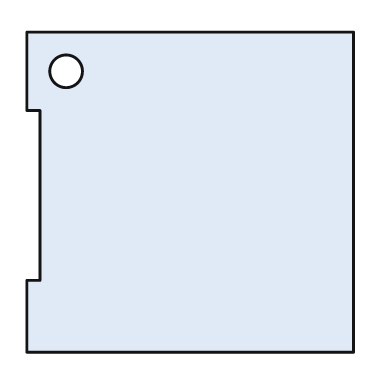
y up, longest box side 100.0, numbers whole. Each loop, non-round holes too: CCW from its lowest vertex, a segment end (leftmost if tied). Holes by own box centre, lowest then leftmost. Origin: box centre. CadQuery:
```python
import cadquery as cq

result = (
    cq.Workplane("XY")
    .moveTo(-50.0, -49.0)
    .lineTo(50.0, -49.0)
    .lineTo(50.0, 49.0)
    .lineTo(-50.0, 49.0)
    .lineTo(-50.0, 25.0)
    .lineTo(-46.0, 25.0)
    .lineTo(-46.0, -27.0)
    .lineTo(-50.0, -27.0)
    .close()
    .moveTo(-38.0, 37.0)
    .circle(5.0)
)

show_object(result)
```